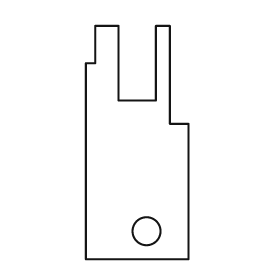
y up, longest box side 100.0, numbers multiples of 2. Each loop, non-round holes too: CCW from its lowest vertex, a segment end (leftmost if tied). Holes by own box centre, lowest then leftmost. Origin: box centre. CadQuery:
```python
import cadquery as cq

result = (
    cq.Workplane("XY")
    .moveTo(-22.0, -50.0)
    .lineTo(22.0, -50.0)
    .lineTo(22.0, 8.0)
    .lineTo(14.0, 8.0)
    .lineTo(14.0, 50.0)
    .lineTo(8.0, 50.0)
    .lineTo(8.0, 18.0)
    .lineTo(-8.0, 18.0)
    .lineTo(-8.0, 50.0)
    .lineTo(-18.0, 50.0)
    .lineTo(-18.0, 34.0)
    .lineTo(-22.0, 34.0)
    .close()
    .moveTo(4.0, -38.0)
    .circle(6.0)
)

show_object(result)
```